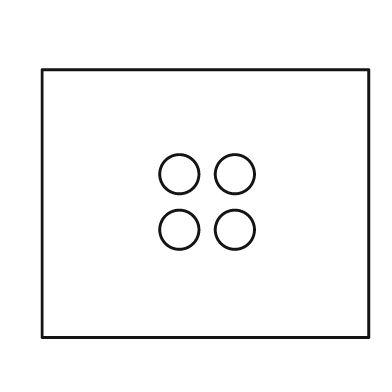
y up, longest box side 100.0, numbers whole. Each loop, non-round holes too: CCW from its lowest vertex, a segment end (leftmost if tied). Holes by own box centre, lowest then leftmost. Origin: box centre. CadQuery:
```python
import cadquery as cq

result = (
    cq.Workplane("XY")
    .moveTo(-50.0, -41.0)
    .lineTo(50.0, -41.0)
    .lineTo(50.0, 41.0)
    .lineTo(-50.0, 41.0)
    .close()
    .moveTo(-8.0, -8.0)
    .circle(6.0)
    .moveTo(9.0, -8.0)
    .circle(6.0)
    .moveTo(-8.0, 9.0)
    .circle(6.0)
    .moveTo(9.0, 9.0)
    .circle(6.0)
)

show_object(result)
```